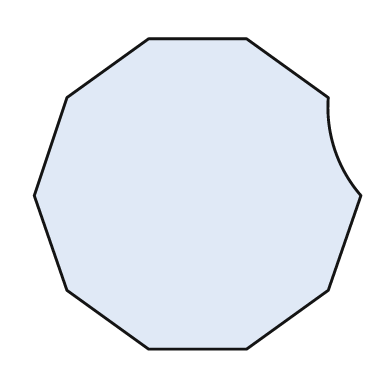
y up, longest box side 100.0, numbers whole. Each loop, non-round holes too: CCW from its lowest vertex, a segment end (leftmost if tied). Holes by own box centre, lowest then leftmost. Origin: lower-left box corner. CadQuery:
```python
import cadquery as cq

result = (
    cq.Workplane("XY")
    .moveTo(35.0, 0.0)
    .lineTo(65.0, 0.0)
    .lineTo(90.0, 18.0)
    .lineTo(100.0, 47.0)
    .threePointArc((92.0, 61.0), (90.0, 77.0))
    .lineTo(65.0, 95.0)
    .lineTo(35.0, 95.0)
    .lineTo(10.0, 77.0)
    .lineTo(0.0, 47.0)
    .lineTo(10.0, 18.0)
    .close()
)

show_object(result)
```